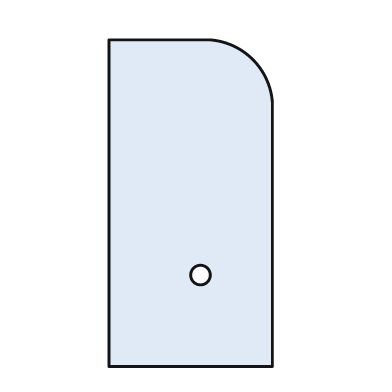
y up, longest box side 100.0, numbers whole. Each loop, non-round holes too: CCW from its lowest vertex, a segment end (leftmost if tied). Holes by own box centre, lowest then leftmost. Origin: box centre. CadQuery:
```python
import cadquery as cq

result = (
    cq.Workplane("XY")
    .moveTo(-25.0, -50.0)
    .lineTo(25.0, -50.0)
    .lineTo(25.0, 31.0)
    .threePointArc((19.0, 44.0), (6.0, 50.0))
    .lineTo(-25.0, 50.0)
    .close()
    .moveTo(3.0, -22.0)
    .circle(3.0)
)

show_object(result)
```